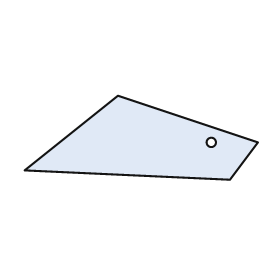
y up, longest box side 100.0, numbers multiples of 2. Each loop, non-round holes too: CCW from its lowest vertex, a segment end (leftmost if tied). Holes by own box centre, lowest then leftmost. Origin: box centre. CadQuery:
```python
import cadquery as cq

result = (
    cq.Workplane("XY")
    .moveTo(38.0, -18.0)
    .lineTo(50.0, -2.0)
    .lineTo(-10.0, 18.0)
    .lineTo(-50.0, -14.0)
    .close()
    .moveTo(30.0, -2.0)
    .circle(2.0)
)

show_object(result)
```